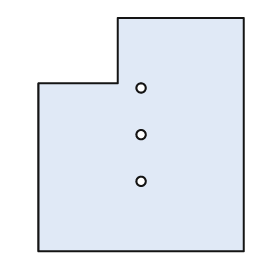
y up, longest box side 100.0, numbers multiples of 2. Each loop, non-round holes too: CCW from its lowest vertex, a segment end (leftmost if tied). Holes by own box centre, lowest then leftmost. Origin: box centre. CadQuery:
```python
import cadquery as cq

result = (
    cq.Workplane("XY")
    .moveTo(-44.0, -50.0)
    .lineTo(44.0, -50.0)
    .lineTo(44.0, 50.0)
    .lineTo(-10.0, 50.0)
    .lineTo(-10.0, 22.0)
    .lineTo(-44.0, 22.0)
    .close()
    .moveTo(0.0, -20.0)
    .circle(2.0)
    .moveTo(0.0, 0.0)
    .circle(2.0)
    .moveTo(0.0, 20.0)
    .circle(2.0)
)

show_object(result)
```